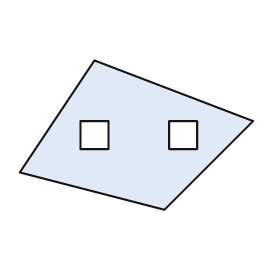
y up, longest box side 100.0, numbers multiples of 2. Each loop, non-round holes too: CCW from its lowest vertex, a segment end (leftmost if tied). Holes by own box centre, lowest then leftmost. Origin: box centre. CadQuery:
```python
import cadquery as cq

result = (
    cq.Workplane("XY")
    .moveTo(12.0, -32.0)
    .lineTo(50.0, 6.0)
    .lineTo(-18.0, 32.0)
    .lineTo(-50.0, -16.0)
    .close()
    .moveTo(-24.0, -6.0)
    .lineTo(-12.0, -6.0)
    .lineTo(-12.0, 6.0)
    .lineTo(-24.0, 6.0)
    .close()
    .moveTo(14.0, -6.0)
    .lineTo(26.0, -6.0)
    .lineTo(26.0, 6.0)
    .lineTo(14.0, 6.0)
    .close()
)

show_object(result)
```